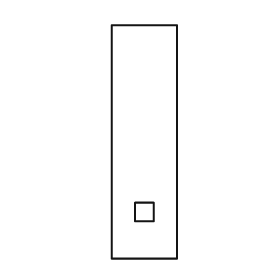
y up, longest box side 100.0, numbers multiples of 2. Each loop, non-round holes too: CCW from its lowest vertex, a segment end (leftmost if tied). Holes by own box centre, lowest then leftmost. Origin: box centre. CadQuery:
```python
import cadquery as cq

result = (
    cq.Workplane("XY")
    .moveTo(-14.0, -50.0)
    .lineTo(14.0, -50.0)
    .lineTo(14.0, 50.0)
    .lineTo(-14.0, 50.0)
    .close()
    .moveTo(-4.0, -34.0)
    .lineTo(4.0, -34.0)
    .lineTo(4.0, -26.0)
    .lineTo(-4.0, -26.0)
    .close()
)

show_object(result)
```